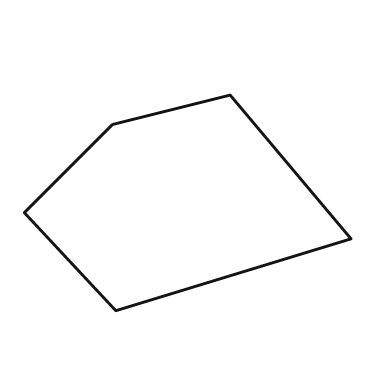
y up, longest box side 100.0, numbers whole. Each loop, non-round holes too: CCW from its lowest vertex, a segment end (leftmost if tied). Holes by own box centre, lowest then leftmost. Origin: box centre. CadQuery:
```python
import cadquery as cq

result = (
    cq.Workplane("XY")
    .moveTo(-22.0, -33.0)
    .lineTo(50.0, -11.0)
    .lineTo(13.0, 33.0)
    .lineTo(-23.0, 24.0)
    .lineTo(-50.0, -3.0)
    .close()
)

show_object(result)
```